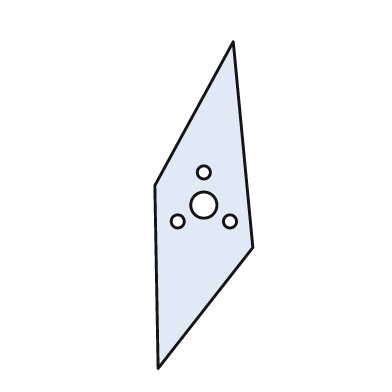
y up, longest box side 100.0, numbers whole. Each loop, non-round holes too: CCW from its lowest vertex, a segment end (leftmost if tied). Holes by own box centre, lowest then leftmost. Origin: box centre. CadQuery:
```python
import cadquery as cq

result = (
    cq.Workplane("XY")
    .moveTo(-14.0, -50.0)
    .lineTo(15.0, -13.0)
    .lineTo(9.0, 50.0)
    .lineTo(-15.0, 6.0)
    .close()
    .moveTo(-8.0, -5.0)
    .circle(2.0)
    .moveTo(8.0, -5.0)
    .circle(2.0)
    .moveTo(0.0, 0.0)
    .circle(4.0)
    .moveTo(0.0, 10.0)
    .circle(2.0)
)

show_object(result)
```